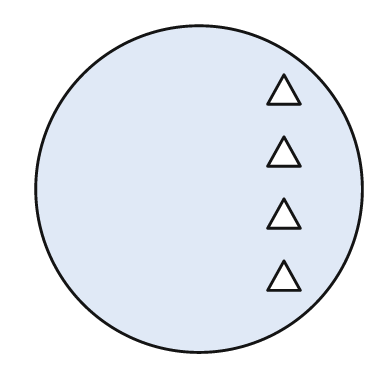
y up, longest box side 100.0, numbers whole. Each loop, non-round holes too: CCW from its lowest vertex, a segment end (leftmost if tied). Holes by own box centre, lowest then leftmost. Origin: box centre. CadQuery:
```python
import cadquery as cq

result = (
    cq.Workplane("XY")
    .moveTo(0.0, 0.0)
    .circle(50.0)
    .moveTo(21.0, -31.0)
    .lineTo(31.0, -31.0)
    .lineTo(26.0, -22.0)
    .close()
    .moveTo(21.0, -12.0)
    .lineTo(31.0, -12.0)
    .lineTo(26.0, -3.0)
    .close()
    .moveTo(21.0, 7.0)
    .lineTo(31.0, 7.0)
    .lineTo(26.0, 16.0)
    .close()
    .moveTo(21.0, 26.0)
    .lineTo(31.0, 26.0)
    .lineTo(26.0, 35.0)
    .close()
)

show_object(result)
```